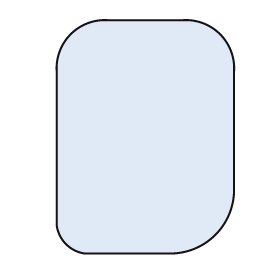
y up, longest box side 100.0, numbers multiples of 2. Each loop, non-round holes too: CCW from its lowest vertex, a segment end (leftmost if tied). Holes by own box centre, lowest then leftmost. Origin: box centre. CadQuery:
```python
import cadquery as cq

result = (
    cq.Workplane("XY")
    .moveTo(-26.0, -50.0)
    .lineTo(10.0, -50.0)
    .threePointArc((30.0, -42.0), (38.0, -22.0))
    .lineTo(38.0, 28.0)
    .threePointArc((32.0, 44.0), (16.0, 50.0))
    .lineTo(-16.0, 50.0)
    .threePointArc((-32.0, 44.0), (-38.0, 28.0))
    .lineTo(-38.0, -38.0)
    .threePointArc((-34.0, -46.0), (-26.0, -50.0))
    .close()
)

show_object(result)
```